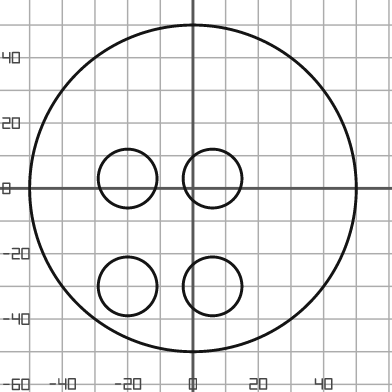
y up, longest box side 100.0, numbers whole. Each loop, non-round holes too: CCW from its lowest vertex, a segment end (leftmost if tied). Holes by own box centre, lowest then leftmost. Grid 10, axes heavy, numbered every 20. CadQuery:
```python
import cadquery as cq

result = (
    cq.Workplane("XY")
    .moveTo(0.0, 0.0)
    .circle(50.0)
    .moveTo(-20.0, -30.0)
    .circle(9.0)
    .moveTo(6.0, -30.0)
    .circle(9.0)
    .moveTo(-20.0, 3.0)
    .circle(9.0)
    .moveTo(6.0, 3.0)
    .circle(9.0)
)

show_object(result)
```